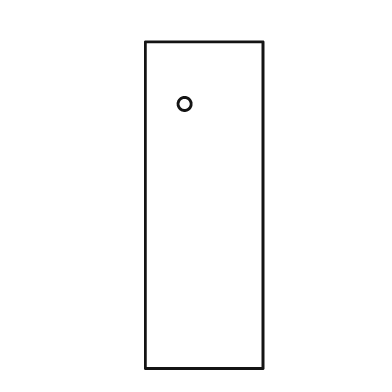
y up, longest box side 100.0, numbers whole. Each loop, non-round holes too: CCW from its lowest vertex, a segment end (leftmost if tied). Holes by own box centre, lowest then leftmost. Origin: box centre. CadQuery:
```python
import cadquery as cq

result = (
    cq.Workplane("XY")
    .moveTo(-18.0, -50.0)
    .lineTo(18.0, -50.0)
    .lineTo(18.0, 50.0)
    .lineTo(-18.0, 50.0)
    .close()
    .moveTo(-6.0, 31.0)
    .circle(2.0)
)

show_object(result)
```